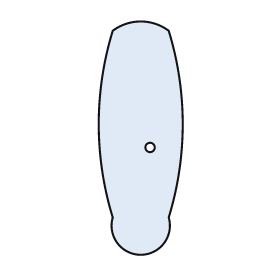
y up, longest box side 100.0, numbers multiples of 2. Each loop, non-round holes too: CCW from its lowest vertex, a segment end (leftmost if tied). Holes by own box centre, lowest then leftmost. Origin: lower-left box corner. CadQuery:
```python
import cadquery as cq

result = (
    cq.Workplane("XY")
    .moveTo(6.0, 16.0)
    .threePointArc((18.0, 0.0), (30.0, 16.0))
    .threePointArc((36.0, 56.0), (30.0, 96.0))
    .threePointArc((18.0, 100.0), (6.0, 96.0))
    .threePointArc((0.0, 56.0), (6.0, 16.0))
    .close()
    .moveTo(22.0, 46.0)
    .circle(2.0)
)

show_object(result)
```